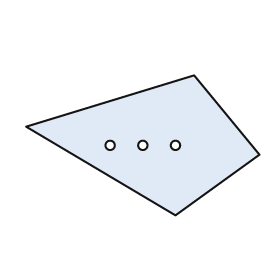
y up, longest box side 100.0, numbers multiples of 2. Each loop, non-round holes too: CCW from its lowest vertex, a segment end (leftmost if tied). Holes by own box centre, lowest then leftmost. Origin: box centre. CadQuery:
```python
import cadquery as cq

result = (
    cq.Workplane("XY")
    .moveTo(14.0, -30.0)
    .lineTo(50.0, -4.0)
    .lineTo(22.0, 30.0)
    .lineTo(-50.0, 8.0)
    .close()
    .moveTo(-14.0, 0.0)
    .circle(2.0)
    .moveTo(0.0, 0.0)
    .circle(2.0)
    .moveTo(14.0, 0.0)
    .circle(2.0)
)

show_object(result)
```